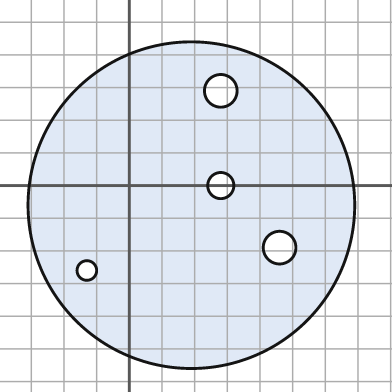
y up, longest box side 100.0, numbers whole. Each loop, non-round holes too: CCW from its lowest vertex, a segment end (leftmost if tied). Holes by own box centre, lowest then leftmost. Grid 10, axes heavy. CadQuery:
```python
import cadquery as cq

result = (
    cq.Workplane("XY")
    .moveTo(19.0, -6.0)
    .circle(50.0)
    .moveTo(-13.0, -26.0)
    .circle(3.0)
    .moveTo(46.0, -19.0)
    .circle(5.0)
    .moveTo(28.0, 0.0)
    .circle(4.0)
    .moveTo(28.0, 29.0)
    .circle(5.0)
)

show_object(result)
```